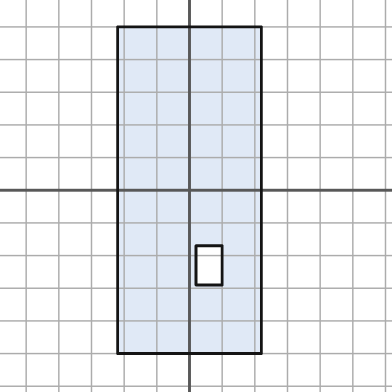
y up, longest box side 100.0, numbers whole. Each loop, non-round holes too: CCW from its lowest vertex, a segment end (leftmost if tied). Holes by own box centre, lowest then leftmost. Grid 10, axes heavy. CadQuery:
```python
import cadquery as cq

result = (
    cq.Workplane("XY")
    .moveTo(-22.0, -50.0)
    .lineTo(22.0, -50.0)
    .lineTo(22.0, 50.0)
    .lineTo(-22.0, 50.0)
    .close()
    .moveTo(2.0, -29.0)
    .lineTo(10.0, -29.0)
    .lineTo(10.0, -17.0)
    .lineTo(2.0, -17.0)
    .close()
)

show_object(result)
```